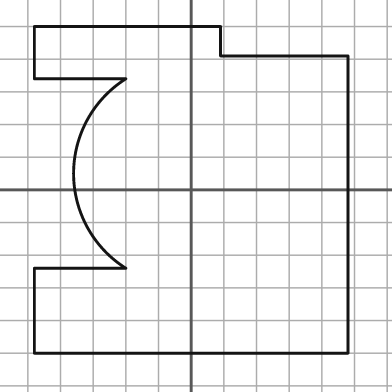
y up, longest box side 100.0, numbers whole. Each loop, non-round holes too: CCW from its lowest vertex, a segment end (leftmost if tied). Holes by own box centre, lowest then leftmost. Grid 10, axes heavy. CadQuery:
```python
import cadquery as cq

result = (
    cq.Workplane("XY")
    .moveTo(-48.0, -50.0)
    .lineTo(48.0, -50.0)
    .lineTo(48.0, 41.0)
    .lineTo(9.0, 41.0)
    .lineTo(9.0, 50.0)
    .lineTo(-48.0, 50.0)
    .lineTo(-48.0, 34.0)
    .lineTo(-20.0, 34.0)
    .threePointArc((-36.0, 5.0), (-20.0, -24.0))
    .lineTo(-48.0, -24.0)
    .close()
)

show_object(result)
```